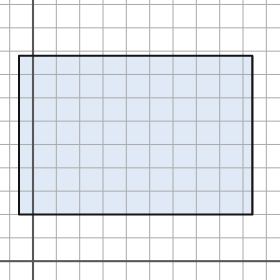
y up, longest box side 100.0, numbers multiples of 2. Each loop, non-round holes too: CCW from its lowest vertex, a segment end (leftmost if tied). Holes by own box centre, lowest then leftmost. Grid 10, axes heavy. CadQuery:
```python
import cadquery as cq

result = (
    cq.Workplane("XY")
    .moveTo(-6.0, 20.0)
    .lineTo(94.0, 20.0)
    .lineTo(94.0, 88.0)
    .lineTo(-6.0, 88.0)
    .close()
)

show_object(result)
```